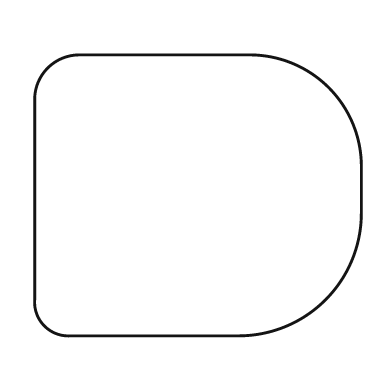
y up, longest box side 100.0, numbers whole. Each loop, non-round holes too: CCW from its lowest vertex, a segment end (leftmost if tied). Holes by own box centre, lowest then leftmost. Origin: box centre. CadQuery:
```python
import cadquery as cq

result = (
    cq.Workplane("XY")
    .moveTo(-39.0, -43.0)
    .lineTo(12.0, -43.0)
    .threePointArc((39.0, -32.0), (50.0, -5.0))
    .lineTo(50.0, 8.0)
    .threePointArc((40.0, 33.0), (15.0, 43.0))
    .lineTo(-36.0, 43.0)
    .threePointArc((-46.0, 39.0), (-50.0, 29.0))
    .lineTo(-50.0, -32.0)
    .threePointArc((-47.0, -40.0), (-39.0, -43.0))
    .close()
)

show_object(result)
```